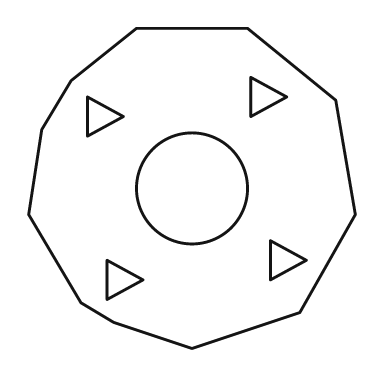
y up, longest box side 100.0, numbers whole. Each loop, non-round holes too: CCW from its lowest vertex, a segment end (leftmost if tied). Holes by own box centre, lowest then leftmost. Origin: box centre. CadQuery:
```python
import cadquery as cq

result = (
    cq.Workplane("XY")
    .moveTo(0.0, -49.0)
    .lineTo(33.0, -38.0)
    .lineTo(50.0, -8.0)
    .lineTo(44.0, 27.0)
    .lineTo(17.0, 49.0)
    .lineTo(-17.0, 49.0)
    .lineTo(-37.0, 33.0)
    .lineTo(-46.0, 18.0)
    .lineTo(-50.0, -8.0)
    .lineTo(-34.0, -35.0)
    .lineTo(-24.0, -41.0)
    .close()
    .moveTo(-26.0, -34.0)
    .lineTo(-15.0, -28.0)
    .lineTo(-26.0, -22.0)
    .close()
    .moveTo(24.0, -28.0)
    .lineTo(35.0, -22.0)
    .lineTo(24.0, -16.0)
    .close()
    .moveTo(0.0, 0.0)
    .circle(17.0)
    .moveTo(-32.0, 16.0)
    .lineTo(-21.0, 22.0)
    .lineTo(-32.0, 28.0)
    .close()
    .moveTo(18.0, 22.0)
    .lineTo(29.0, 28.0)
    .lineTo(18.0, 34.0)
    .close()
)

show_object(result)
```